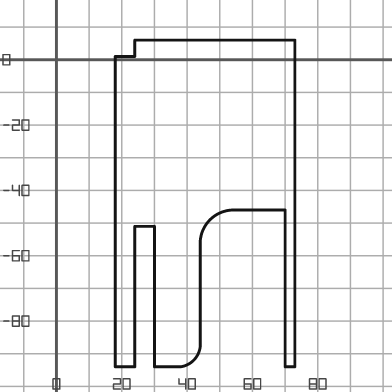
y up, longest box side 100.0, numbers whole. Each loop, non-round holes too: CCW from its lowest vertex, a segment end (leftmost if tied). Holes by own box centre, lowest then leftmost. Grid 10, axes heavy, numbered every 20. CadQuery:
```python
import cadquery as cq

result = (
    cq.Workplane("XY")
    .moveTo(18.0, -94.0)
    .lineTo(24.0, -94.0)
    .lineTo(24.0, -51.0)
    .lineTo(30.0, -51.0)
    .lineTo(30.0, -94.0)
    .lineTo(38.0, -94.0)
    .threePointArc((42.0, -92.0), (44.0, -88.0))
    .lineTo(44.0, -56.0)
    .threePointArc((47.0, -49.0), (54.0, -46.0))
    .lineTo(70.0, -46.0)
    .lineTo(70.0, -94.0)
    .lineTo(73.0, -94.0)
    .lineTo(73.0, 6.0)
    .lineTo(24.0, 6.0)
    .lineTo(24.0, 1.0)
    .lineTo(18.0, 1.0)
    .close()
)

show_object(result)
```